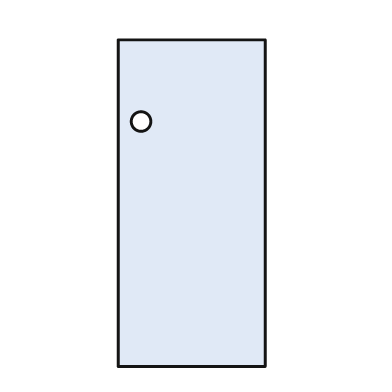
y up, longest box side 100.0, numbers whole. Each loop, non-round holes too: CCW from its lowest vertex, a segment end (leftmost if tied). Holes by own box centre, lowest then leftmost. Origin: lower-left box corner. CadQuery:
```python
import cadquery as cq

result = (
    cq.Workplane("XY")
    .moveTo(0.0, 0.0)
    .lineTo(45.0, 0.0)
    .lineTo(45.0, 100.0)
    .lineTo(0.0, 100.0)
    .close()
    .moveTo(7.0, 75.0)
    .circle(3.0)
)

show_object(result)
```